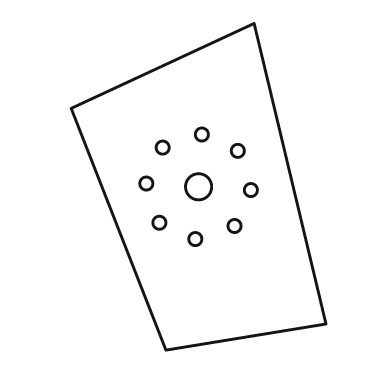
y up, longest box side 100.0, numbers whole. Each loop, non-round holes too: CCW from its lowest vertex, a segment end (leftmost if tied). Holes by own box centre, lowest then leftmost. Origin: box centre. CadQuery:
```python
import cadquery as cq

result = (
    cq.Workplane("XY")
    .moveTo(-10.0, -50.0)
    .lineTo(39.0, -42.0)
    .lineTo(17.0, 50.0)
    .lineTo(-39.0, 24.0)
    .close()
    .moveTo(-1.0, -16.0)
    .circle(2.0)
    .moveTo(11.0, -12.0)
    .circle(2.0)
    .moveTo(-12.0, -11.0)
    .circle(2.0)
    .moveTo(16.0, -1.0)
    .circle(2.0)
    .moveTo(0.0, 0.0)
    .circle(4.0)
    .moveTo(-16.0, 1.0)
    .circle(2.0)
    .moveTo(12.0, 11.0)
    .circle(2.0)
    .moveTo(-11.0, 12.0)
    .circle(2.0)
    .moveTo(1.0, 16.0)
    .circle(2.0)
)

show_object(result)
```